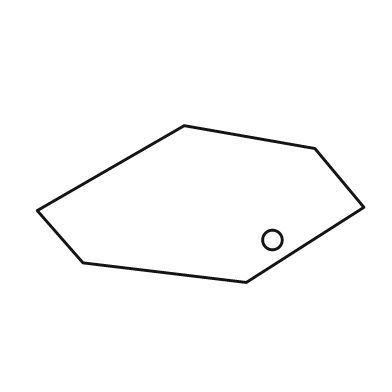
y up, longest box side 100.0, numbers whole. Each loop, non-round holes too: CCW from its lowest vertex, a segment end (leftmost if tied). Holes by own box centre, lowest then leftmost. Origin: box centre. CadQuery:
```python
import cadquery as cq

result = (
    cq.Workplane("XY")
    .moveTo(14.0, -24.0)
    .lineTo(50.0, -1.0)
    .lineTo(35.0, 17.0)
    .lineTo(-5.0, 24.0)
    .lineTo(-50.0, -2.0)
    .lineTo(-36.0, -18.0)
    .close()
    .moveTo(22.0, -11.0)
    .circle(3.0)
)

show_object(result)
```